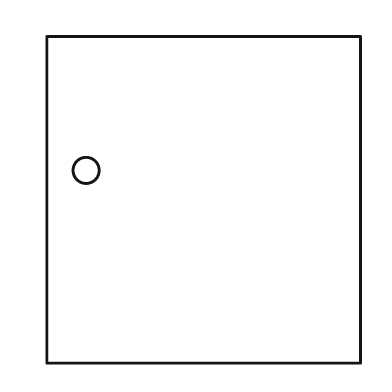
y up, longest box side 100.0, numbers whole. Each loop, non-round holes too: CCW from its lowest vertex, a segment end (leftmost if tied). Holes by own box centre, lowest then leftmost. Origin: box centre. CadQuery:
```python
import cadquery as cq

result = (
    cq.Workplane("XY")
    .moveTo(-48.0, -50.0)
    .lineTo(48.0, -50.0)
    .lineTo(48.0, 50.0)
    .lineTo(-48.0, 50.0)
    .close()
    .moveTo(-36.0, 9.0)
    .circle(4.0)
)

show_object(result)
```